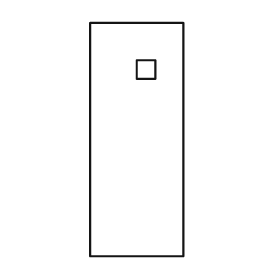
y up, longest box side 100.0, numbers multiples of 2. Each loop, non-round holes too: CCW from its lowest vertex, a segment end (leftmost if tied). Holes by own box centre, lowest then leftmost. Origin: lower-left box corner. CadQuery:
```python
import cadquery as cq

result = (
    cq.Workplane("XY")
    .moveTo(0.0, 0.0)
    .lineTo(40.0, 0.0)
    .lineTo(40.0, 100.0)
    .lineTo(0.0, 100.0)
    .close()
    .moveTo(20.0, 76.0)
    .lineTo(28.0, 76.0)
    .lineTo(28.0, 84.0)
    .lineTo(20.0, 84.0)
    .close()
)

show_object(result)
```